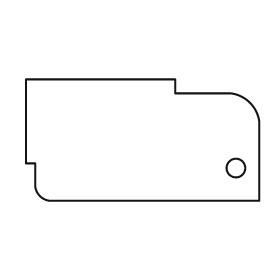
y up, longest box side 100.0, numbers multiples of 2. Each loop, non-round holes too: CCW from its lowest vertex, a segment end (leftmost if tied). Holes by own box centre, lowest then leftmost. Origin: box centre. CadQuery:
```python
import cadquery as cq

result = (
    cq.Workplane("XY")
    .moveTo(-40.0, -26.0)
    .lineTo(50.0, -26.0)
    .lineTo(50.0, 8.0)
    .threePointArc((46.0, 16.0), (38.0, 20.0))
    .lineTo(14.0, 20.0)
    .lineTo(14.0, 26.0)
    .lineTo(-50.0, 26.0)
    .lineTo(-50.0, -10.0)
    .lineTo(-46.0, -10.0)
    .lineTo(-46.0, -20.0)
    .threePointArc((-44.0, -24.0), (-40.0, -26.0))
    .close()
    .moveTo(40.0, -12.0)
    .circle(4.0)
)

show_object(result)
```